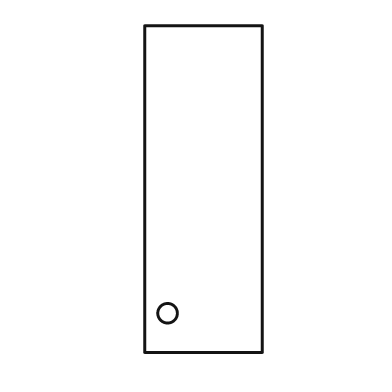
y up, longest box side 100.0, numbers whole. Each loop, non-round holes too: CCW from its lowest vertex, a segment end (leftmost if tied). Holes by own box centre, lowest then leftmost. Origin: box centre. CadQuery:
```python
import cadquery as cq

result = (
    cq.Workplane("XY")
    .moveTo(-18.0, -50.0)
    .lineTo(18.0, -50.0)
    .lineTo(18.0, 50.0)
    .lineTo(-18.0, 50.0)
    .close()
    .moveTo(-11.0, -38.0)
    .circle(3.0)
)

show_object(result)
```